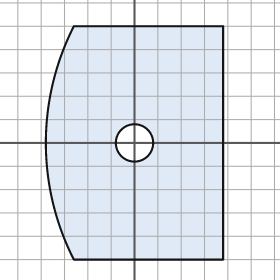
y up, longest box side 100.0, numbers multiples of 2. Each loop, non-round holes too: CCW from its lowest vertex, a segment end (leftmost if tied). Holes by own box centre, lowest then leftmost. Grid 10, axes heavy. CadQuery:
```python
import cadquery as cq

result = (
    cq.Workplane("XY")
    .moveTo(-26.0, -50.0)
    .lineTo(38.0, -50.0)
    .lineTo(38.0, 50.0)
    .lineTo(-26.0, 50.0)
    .threePointArc((-38.0, 0.0), (-26.0, -50.0))
    .close()
    .moveTo(0.0, 0.0)
    .circle(8.0)
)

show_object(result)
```